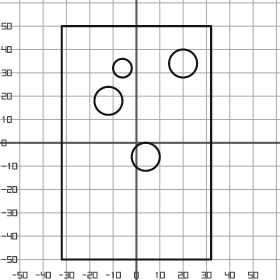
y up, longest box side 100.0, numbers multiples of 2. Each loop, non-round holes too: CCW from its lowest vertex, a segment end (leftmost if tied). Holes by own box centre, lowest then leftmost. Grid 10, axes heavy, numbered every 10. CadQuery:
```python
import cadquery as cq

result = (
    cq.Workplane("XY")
    .moveTo(-32.0, -50.0)
    .lineTo(32.0, -50.0)
    .lineTo(32.0, 50.0)
    .lineTo(-32.0, 50.0)
    .close()
    .moveTo(4.0, -6.0)
    .circle(6.0)
    .moveTo(-12.0, 18.0)
    .circle(6.0)
    .moveTo(-6.0, 32.0)
    .circle(4.0)
    .moveTo(20.0, 34.0)
    .circle(6.0)
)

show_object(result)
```